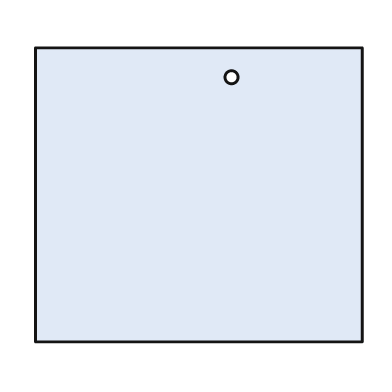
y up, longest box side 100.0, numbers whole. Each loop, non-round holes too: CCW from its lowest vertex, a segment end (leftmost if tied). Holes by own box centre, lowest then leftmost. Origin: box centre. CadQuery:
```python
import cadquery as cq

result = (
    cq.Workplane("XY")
    .moveTo(-50.0, -45.0)
    .lineTo(50.0, -45.0)
    .lineTo(50.0, 45.0)
    .lineTo(-50.0, 45.0)
    .close()
    .moveTo(10.0, 36.0)
    .circle(2.0)
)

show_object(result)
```